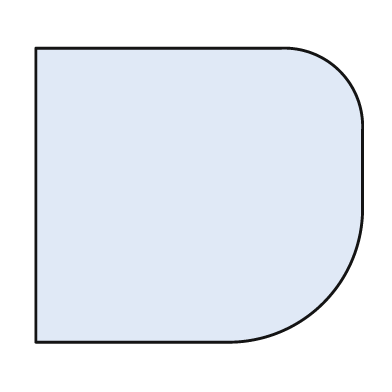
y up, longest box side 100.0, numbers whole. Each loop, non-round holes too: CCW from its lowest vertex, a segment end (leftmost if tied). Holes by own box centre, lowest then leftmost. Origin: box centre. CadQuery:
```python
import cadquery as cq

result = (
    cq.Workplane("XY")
    .moveTo(-50.0, -45.0)
    .lineTo(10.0, -45.0)
    .threePointArc((38.0, -33.0), (50.0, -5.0))
    .lineTo(50.0, 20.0)
    .threePointArc((43.0, 38.0), (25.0, 45.0))
    .lineTo(-50.0, 45.0)
    .close()
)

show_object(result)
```